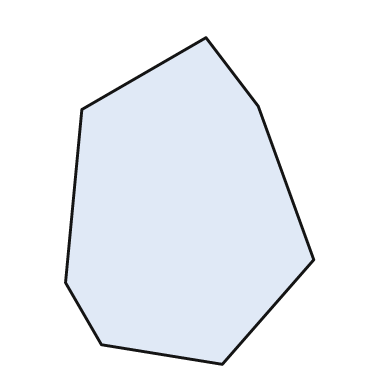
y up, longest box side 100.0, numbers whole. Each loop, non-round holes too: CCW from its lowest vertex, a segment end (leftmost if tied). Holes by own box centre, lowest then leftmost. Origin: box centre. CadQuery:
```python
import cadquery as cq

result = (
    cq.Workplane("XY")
    .moveTo(10.0, -50.0)
    .lineTo(38.0, -18.0)
    .lineTo(21.0, 29.0)
    .lineTo(5.0, 50.0)
    .lineTo(-33.0, 28.0)
    .lineTo(-38.0, -25.0)
    .lineTo(-27.0, -44.0)
    .close()
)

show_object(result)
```